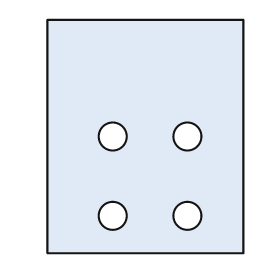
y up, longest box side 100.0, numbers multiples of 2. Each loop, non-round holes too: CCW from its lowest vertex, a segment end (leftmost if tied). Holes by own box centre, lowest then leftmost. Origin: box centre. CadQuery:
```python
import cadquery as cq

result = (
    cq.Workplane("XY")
    .moveTo(-42.0, -50.0)
    .lineTo(42.0, -50.0)
    .lineTo(42.0, 50.0)
    .lineTo(-42.0, 50.0)
    .close()
    .moveTo(-14.0, -34.0)
    .circle(6.0)
    .moveTo(18.0, -34.0)
    .circle(6.0)
    .moveTo(-14.0, 0.0)
    .circle(6.0)
    .moveTo(18.0, 0.0)
    .circle(6.0)
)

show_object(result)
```